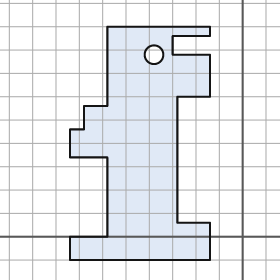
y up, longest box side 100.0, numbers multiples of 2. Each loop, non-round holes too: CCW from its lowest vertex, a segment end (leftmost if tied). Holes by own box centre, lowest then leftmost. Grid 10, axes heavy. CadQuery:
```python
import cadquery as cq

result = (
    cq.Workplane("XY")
    .moveTo(-74.0, -10.0)
    .lineTo(-14.0, -10.0)
    .lineTo(-14.0, 6.0)
    .lineTo(-28.0, 6.0)
    .lineTo(-28.0, 60.0)
    .lineTo(-14.0, 60.0)
    .lineTo(-14.0, 78.0)
    .lineTo(-30.0, 78.0)
    .lineTo(-30.0, 86.0)
    .lineTo(-14.0, 86.0)
    .lineTo(-14.0, 90.0)
    .lineTo(-58.0, 90.0)
    .lineTo(-58.0, 56.0)
    .lineTo(-68.0, 56.0)
    .lineTo(-68.0, 46.0)
    .lineTo(-74.0, 46.0)
    .lineTo(-74.0, 34.0)
    .lineTo(-58.0, 34.0)
    .lineTo(-58.0, 0.0)
    .lineTo(-74.0, 0.0)
    .close()
    .moveTo(-38.0, 78.0)
    .circle(4.0)
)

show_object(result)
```